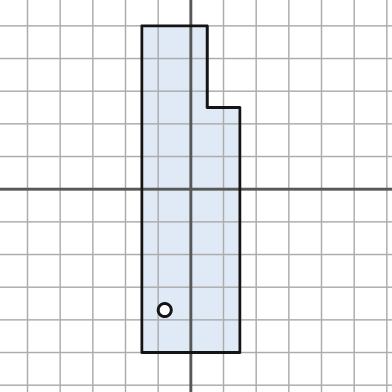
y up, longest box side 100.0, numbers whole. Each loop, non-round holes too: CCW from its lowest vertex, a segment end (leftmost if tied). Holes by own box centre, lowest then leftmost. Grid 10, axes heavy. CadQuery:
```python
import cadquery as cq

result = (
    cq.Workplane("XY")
    .moveTo(-15.0, -50.0)
    .lineTo(15.0, -50.0)
    .lineTo(15.0, 25.0)
    .lineTo(5.0, 25.0)
    .lineTo(5.0, 50.0)
    .lineTo(-15.0, 50.0)
    .close()
    .moveTo(-8.0, -37.0)
    .circle(2.0)
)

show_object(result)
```